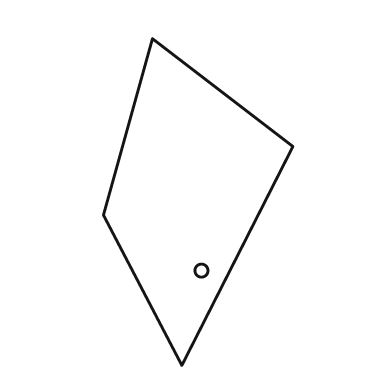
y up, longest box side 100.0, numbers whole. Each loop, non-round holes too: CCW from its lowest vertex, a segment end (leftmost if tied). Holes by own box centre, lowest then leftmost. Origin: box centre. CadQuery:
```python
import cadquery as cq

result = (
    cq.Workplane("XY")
    .moveTo(-5.0, -50.0)
    .lineTo(29.0, 17.0)
    .lineTo(-14.0, 50.0)
    .lineTo(-29.0, -4.0)
    .close()
    .moveTo(1.0, -21.0)
    .circle(2.0)
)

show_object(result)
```